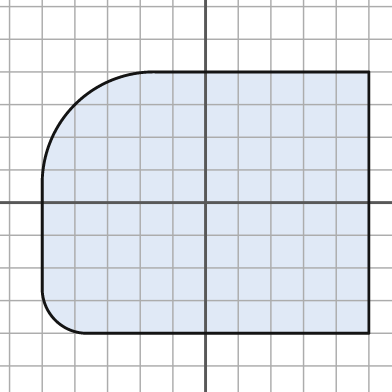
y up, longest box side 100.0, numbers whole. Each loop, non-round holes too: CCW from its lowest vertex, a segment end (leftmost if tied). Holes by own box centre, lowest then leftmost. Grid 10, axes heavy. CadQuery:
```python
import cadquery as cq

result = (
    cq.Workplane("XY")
    .moveTo(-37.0, -40.0)
    .lineTo(50.0, -40.0)
    .lineTo(50.0, 40.0)
    .lineTo(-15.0, 40.0)
    .threePointArc((-40.0, 30.0), (-50.0, 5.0))
    .lineTo(-50.0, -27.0)
    .threePointArc((-46.0, -36.0), (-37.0, -40.0))
    .close()
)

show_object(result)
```